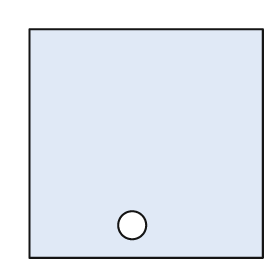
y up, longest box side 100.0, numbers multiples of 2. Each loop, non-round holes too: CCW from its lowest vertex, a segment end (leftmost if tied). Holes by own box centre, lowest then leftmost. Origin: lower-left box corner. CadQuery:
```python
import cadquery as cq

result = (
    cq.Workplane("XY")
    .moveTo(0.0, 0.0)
    .lineTo(100.0, 0.0)
    .lineTo(100.0, 98.0)
    .lineTo(0.0, 98.0)
    .close()
    .moveTo(44.0, 14.0)
    .circle(6.0)
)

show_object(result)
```